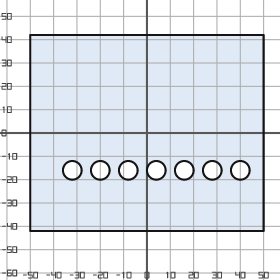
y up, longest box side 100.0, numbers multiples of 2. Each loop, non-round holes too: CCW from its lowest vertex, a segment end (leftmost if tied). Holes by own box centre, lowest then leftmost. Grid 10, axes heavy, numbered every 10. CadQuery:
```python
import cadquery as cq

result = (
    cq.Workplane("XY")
    .moveTo(-50.0, -42.0)
    .lineTo(50.0, -42.0)
    .lineTo(50.0, 42.0)
    .lineTo(-50.0, 42.0)
    .close()
    .moveTo(-32.0, -16.0)
    .circle(4.0)
    .moveTo(-20.0, -16.0)
    .circle(4.0)
    .moveTo(-8.0, -16.0)
    .circle(4.0)
    .moveTo(4.0, -16.0)
    .circle(4.0)
    .moveTo(16.0, -16.0)
    .circle(4.0)
    .moveTo(28.0, -16.0)
    .circle(4.0)
    .moveTo(40.0, -16.0)
    .circle(4.0)
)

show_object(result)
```